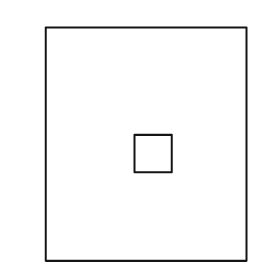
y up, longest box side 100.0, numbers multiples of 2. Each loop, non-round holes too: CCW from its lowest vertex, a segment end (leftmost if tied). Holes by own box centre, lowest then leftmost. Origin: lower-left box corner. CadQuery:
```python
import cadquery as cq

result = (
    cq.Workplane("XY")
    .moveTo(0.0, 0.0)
    .lineTo(86.0, 0.0)
    .lineTo(86.0, 100.0)
    .lineTo(0.0, 100.0)
    .close()
    .moveTo(38.0, 38.0)
    .lineTo(54.0, 38.0)
    .lineTo(54.0, 54.0)
    .lineTo(38.0, 54.0)
    .close()
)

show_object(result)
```